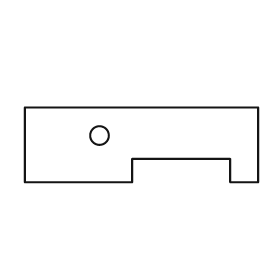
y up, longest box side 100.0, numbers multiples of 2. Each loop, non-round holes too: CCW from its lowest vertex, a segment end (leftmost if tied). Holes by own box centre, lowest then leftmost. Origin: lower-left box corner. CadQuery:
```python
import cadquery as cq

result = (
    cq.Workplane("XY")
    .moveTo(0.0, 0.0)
    .lineTo(46.0, 0.0)
    .lineTo(46.0, 10.0)
    .lineTo(88.0, 10.0)
    .lineTo(88.0, 0.0)
    .lineTo(100.0, 0.0)
    .lineTo(100.0, 32.0)
    .lineTo(0.0, 32.0)
    .close()
    .moveTo(32.0, 20.0)
    .circle(4.0)
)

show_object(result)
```